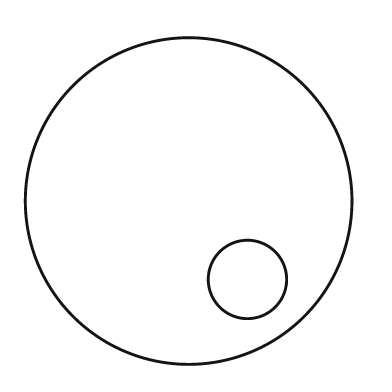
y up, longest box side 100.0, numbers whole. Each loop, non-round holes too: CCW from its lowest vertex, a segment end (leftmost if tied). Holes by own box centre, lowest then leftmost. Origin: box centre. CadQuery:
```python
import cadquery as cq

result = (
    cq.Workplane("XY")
    .moveTo(0.0, 0.0)
    .circle(50.0)
    .moveTo(18.0, -24.0)
    .circle(12.0)
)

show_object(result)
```